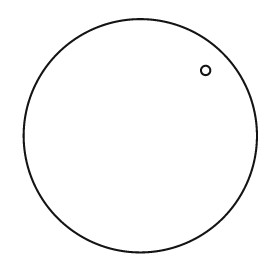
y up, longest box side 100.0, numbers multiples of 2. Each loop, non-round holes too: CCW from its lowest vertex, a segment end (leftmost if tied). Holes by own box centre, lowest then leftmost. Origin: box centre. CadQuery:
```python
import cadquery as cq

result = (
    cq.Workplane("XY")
    .moveTo(0.0, 0.0)
    .circle(50.0)
    .moveTo(28.0, 28.0)
    .circle(2.0)
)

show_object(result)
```